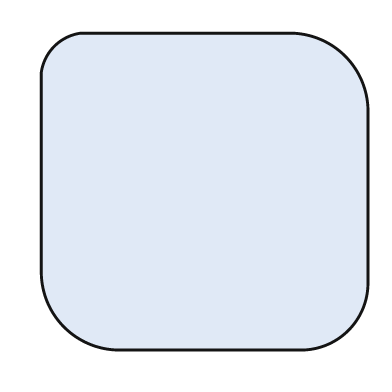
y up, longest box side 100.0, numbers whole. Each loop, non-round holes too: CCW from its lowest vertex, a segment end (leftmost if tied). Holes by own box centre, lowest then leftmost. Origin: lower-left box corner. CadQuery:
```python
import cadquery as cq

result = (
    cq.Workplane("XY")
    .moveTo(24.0, 0.0)
    .lineTo(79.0, 0.0)
    .threePointArc((94.0, 6.0), (100.0, 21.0))
    .lineTo(100.0, 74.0)
    .threePointArc((93.0, 90.0), (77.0, 97.0))
    .lineTo(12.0, 97.0)
    .threePointArc((4.0, 93.0), (0.0, 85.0))
    .lineTo(0.0, 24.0)
    .threePointArc((7.0, 7.0), (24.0, 0.0))
    .close()
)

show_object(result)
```